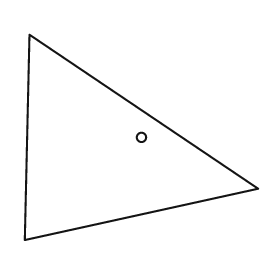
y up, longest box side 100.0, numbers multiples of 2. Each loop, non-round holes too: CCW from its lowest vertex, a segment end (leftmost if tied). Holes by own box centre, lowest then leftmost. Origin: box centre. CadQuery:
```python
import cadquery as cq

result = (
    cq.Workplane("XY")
    .moveTo(-50.0, -44.0)
    .lineTo(50.0, -22.0)
    .lineTo(-48.0, 44.0)
    .close()
    .moveTo(0.0, 0.0)
    .circle(2.0)
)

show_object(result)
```